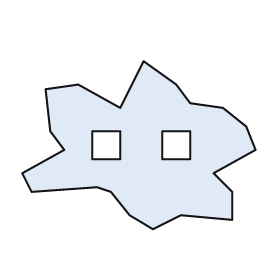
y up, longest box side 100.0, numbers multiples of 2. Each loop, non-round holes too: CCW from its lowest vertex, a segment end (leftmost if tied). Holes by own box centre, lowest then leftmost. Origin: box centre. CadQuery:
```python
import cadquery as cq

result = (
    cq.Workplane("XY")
    .moveTo(6.0, -36.0)
    .lineTo(18.0, -30.0)
    .lineTo(40.0, -32.0)
    .lineTo(40.0, -20.0)
    .lineTo(32.0, -12.0)
    .lineTo(50.0, -2.0)
    .lineTo(46.0, 8.0)
    .lineTo(36.0, 16.0)
    .lineTo(22.0, 18.0)
    .lineTo(16.0, 26.0)
    .lineTo(2.0, 36.0)
    .lineTo(-8.0, 16.0)
    .lineTo(-26.0, 26.0)
    .lineTo(-40.0, 24.0)
    .lineTo(-38.0, 6.0)
    .lineTo(-32.0, -2.0)
    .lineTo(-50.0, -12.0)
    .lineTo(-46.0, -20.0)
    .lineTo(-18.0, -18.0)
    .lineTo(-12.0, -20.0)
    .lineTo(-4.0, -30.0)
    .close()
    .moveTo(-20.0, -6.0)
    .lineTo(-8.0, -6.0)
    .lineTo(-8.0, 6.0)
    .lineTo(-20.0, 6.0)
    .close()
    .moveTo(10.0, -6.0)
    .lineTo(22.0, -6.0)
    .lineTo(22.0, 6.0)
    .lineTo(10.0, 6.0)
    .close()
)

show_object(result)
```